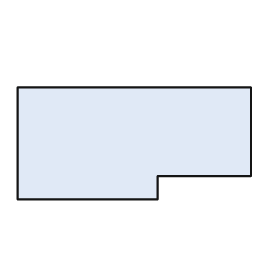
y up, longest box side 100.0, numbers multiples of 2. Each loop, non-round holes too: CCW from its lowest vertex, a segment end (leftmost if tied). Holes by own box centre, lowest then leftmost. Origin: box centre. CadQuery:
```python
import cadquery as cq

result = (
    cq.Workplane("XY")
    .moveTo(-50.0, -24.0)
    .lineTo(10.0, -24.0)
    .lineTo(10.0, -14.0)
    .lineTo(50.0, -14.0)
    .lineTo(50.0, 24.0)
    .lineTo(-50.0, 24.0)
    .close()
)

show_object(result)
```